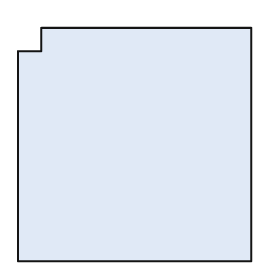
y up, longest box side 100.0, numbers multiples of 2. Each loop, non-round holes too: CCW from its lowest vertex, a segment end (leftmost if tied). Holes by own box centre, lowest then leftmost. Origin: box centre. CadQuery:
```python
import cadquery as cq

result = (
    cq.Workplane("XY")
    .moveTo(-50.0, -50.0)
    .lineTo(50.0, -50.0)
    .lineTo(50.0, 50.0)
    .lineTo(-40.0, 50.0)
    .lineTo(-40.0, 40.0)
    .lineTo(-50.0, 40.0)
    .close()
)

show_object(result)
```